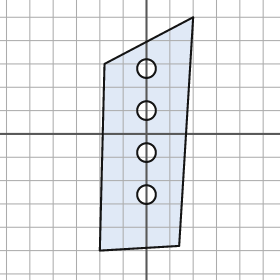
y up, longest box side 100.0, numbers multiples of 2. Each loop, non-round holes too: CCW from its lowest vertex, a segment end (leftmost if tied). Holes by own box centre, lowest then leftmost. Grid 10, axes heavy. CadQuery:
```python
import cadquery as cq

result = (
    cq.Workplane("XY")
    .moveTo(-20.0, -50.0)
    .lineTo(14.0, -48.0)
    .lineTo(20.0, 50.0)
    .lineTo(-18.0, 30.0)
    .close()
    .moveTo(0.0, -26.0)
    .circle(4.0)
    .moveTo(0.0, -8.0)
    .circle(4.0)
    .moveTo(0.0, 10.0)
    .circle(4.0)
    .moveTo(0.0, 28.0)
    .circle(4.0)
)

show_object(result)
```